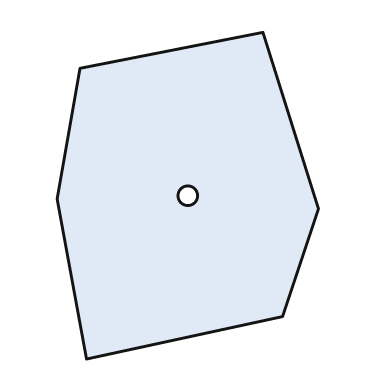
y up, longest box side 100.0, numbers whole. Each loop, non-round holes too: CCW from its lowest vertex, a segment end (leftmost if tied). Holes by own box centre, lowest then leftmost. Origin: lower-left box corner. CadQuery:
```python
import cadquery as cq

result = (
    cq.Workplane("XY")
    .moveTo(9.0, 0.0)
    .lineTo(69.0, 13.0)
    .lineTo(80.0, 46.0)
    .lineTo(63.0, 100.0)
    .lineTo(7.0, 89.0)
    .lineTo(0.0, 49.0)
    .close()
    .moveTo(40.0, 50.0)
    .circle(3.0)
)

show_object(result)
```